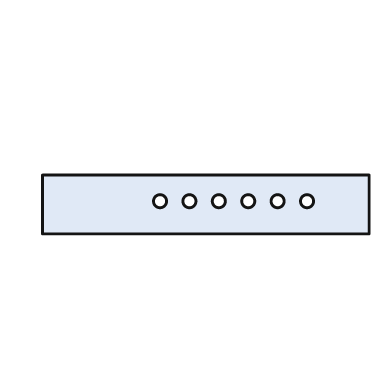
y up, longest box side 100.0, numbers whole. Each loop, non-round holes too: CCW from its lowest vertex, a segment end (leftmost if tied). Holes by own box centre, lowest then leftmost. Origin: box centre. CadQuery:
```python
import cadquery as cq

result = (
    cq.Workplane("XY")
    .moveTo(-50.0, -9.0)
    .lineTo(50.0, -9.0)
    .lineTo(50.0, 9.0)
    .lineTo(-50.0, 9.0)
    .close()
    .moveTo(-14.0, 1.0)
    .circle(2.0)
    .moveTo(-5.0, 1.0)
    .circle(2.0)
    .moveTo(4.0, 1.0)
    .circle(2.0)
    .moveTo(13.0, 1.0)
    .circle(2.0)
    .moveTo(22.0, 1.0)
    .circle(2.0)
    .moveTo(31.0, 1.0)
    .circle(2.0)
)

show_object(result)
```